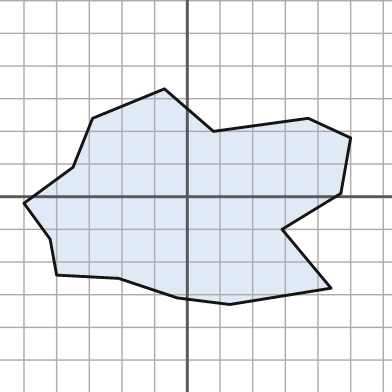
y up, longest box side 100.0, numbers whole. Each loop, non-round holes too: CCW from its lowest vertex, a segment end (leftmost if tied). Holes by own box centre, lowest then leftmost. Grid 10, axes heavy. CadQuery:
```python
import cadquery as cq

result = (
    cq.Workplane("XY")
    .moveTo(13.0, -33.0)
    .lineTo(44.0, -28.0)
    .lineTo(29.0, -10.0)
    .lineTo(47.0, 1.0)
    .lineTo(50.0, 18.0)
    .lineTo(37.0, 24.0)
    .lineTo(8.0, 20.0)
    .lineTo(-7.0, 33.0)
    .lineTo(-29.0, 24.0)
    .lineTo(-35.0, 9.0)
    .lineTo(-50.0, -2.0)
    .lineTo(-42.0, -13.0)
    .lineTo(-40.0, -24.0)
    .lineTo(-21.0, -25.0)
    .lineTo(-3.0, -31.0)
    .close()
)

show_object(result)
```